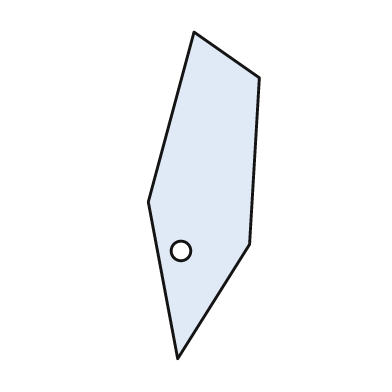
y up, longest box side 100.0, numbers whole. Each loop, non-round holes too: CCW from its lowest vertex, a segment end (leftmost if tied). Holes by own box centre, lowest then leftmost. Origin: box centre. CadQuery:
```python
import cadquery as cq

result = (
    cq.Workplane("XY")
    .moveTo(-8.0, -50.0)
    .lineTo(14.0, -15.0)
    .lineTo(17.0, 36.0)
    .lineTo(-3.0, 50.0)
    .lineTo(-17.0, -2.0)
    .close()
    .moveTo(-7.0, -17.0)
    .circle(3.0)
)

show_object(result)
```